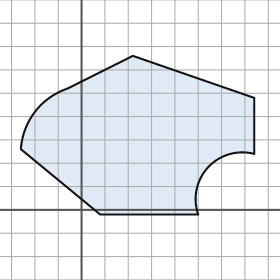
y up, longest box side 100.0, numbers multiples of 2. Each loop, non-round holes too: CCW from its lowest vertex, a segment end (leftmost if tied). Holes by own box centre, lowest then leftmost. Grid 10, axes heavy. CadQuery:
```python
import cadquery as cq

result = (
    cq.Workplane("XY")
    .moveTo(8.0, -2.0)
    .lineTo(50.0, -2.0)
    .threePointArc((54.0, 18.0), (74.0, 24.0))
    .lineTo(74.0, 48.0)
    .lineTo(22.0, 66.0)
    .lineTo(-6.0, 52.0)
    .threePointArc((-20.0, 42.0), (-26.0, 26.0))
    .close()
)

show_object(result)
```